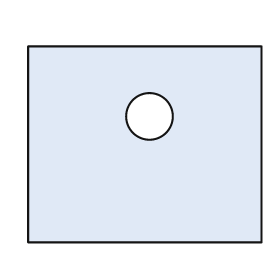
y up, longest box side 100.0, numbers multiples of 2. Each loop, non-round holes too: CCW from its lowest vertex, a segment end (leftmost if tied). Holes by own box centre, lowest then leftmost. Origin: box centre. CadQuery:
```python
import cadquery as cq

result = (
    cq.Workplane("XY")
    .moveTo(-50.0, -42.0)
    .lineTo(50.0, -42.0)
    .lineTo(50.0, 42.0)
    .lineTo(-50.0, 42.0)
    .close()
    .moveTo(2.0, 12.0)
    .circle(10.0)
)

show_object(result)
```